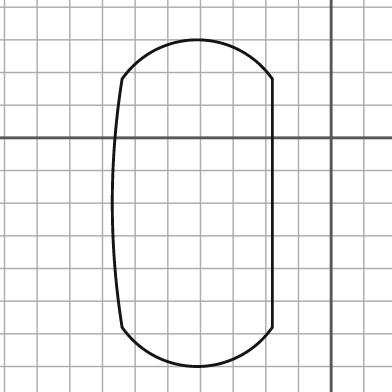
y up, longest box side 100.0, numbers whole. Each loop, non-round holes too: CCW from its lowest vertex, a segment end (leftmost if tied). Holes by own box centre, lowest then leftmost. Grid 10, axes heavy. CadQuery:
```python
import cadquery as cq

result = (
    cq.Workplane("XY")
    .moveTo(-64.0, -58.0)
    .threePointArc((-41.0, -70.0), (-18.0, -58.0))
    .lineTo(-18.0, 18.0)
    .threePointArc((-41.0, 30.0), (-64.0, 18.0))
    .threePointArc((-67.0, -20.0), (-64.0, -58.0))
    .close()
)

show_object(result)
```